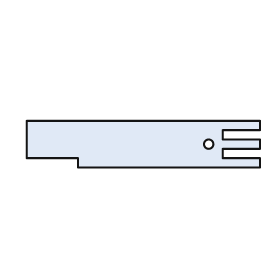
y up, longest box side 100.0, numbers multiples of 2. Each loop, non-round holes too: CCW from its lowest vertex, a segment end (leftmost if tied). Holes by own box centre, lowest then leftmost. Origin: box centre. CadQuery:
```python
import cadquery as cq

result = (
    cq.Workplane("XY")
    .moveTo(-28.0, -10.0)
    .lineTo(50.0, -10.0)
    .lineTo(50.0, -6.0)
    .lineTo(34.0, -6.0)
    .lineTo(34.0, -2.0)
    .lineTo(50.0, -2.0)
    .lineTo(50.0, 2.0)
    .lineTo(34.0, 2.0)
    .lineTo(34.0, 6.0)
    .lineTo(50.0, 6.0)
    .lineTo(50.0, 10.0)
    .lineTo(-50.0, 10.0)
    .lineTo(-50.0, -6.0)
    .lineTo(-28.0, -6.0)
    .close()
    .moveTo(28.0, 0.0)
    .circle(2.0)
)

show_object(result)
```